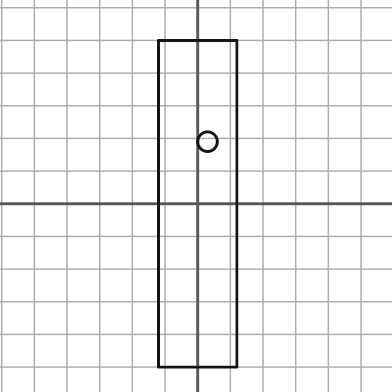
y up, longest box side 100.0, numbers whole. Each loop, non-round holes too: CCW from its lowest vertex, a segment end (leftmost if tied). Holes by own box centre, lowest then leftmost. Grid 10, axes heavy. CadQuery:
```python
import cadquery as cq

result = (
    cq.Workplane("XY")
    .moveTo(-12.0, -50.0)
    .lineTo(12.0, -50.0)
    .lineTo(12.0, 50.0)
    .lineTo(-12.0, 50.0)
    .close()
    .moveTo(3.0, 19.0)
    .circle(3.0)
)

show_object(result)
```